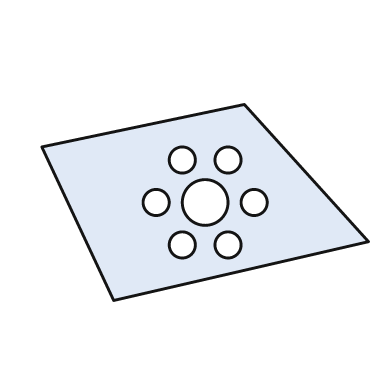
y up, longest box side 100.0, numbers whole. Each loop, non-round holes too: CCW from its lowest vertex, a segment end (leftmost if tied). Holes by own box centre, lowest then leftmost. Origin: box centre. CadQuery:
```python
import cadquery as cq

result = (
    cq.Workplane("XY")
    .moveTo(-28.0, -30.0)
    .lineTo(50.0, -12.0)
    .lineTo(12.0, 30.0)
    .lineTo(-50.0, 17.0)
    .close()
    .moveTo(-7.0, -13.0)
    .circle(4.0)
    .moveTo(7.0, -13.0)
    .circle(4.0)
    .moveTo(-15.0, 0.0)
    .circle(4.0)
    .moveTo(0.0, 0.0)
    .circle(7.0)
    .moveTo(15.0, 0.0)
    .circle(4.0)
    .moveTo(-7.0, 13.0)
    .circle(4.0)
    .moveTo(7.0, 13.0)
    .circle(4.0)
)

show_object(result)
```